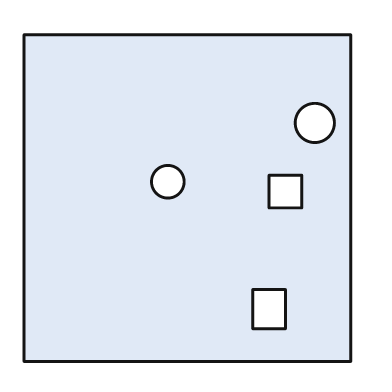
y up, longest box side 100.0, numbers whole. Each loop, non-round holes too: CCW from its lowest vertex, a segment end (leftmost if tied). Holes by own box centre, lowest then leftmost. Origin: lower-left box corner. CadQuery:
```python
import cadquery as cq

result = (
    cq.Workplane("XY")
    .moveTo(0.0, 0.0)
    .lineTo(100.0, 0.0)
    .lineTo(100.0, 100.0)
    .lineTo(0.0, 100.0)
    .close()
    .moveTo(70.0, 10.0)
    .lineTo(80.0, 10.0)
    .lineTo(80.0, 22.0)
    .lineTo(70.0, 22.0)
    .close()
    .moveTo(75.0, 47.0)
    .lineTo(85.0, 47.0)
    .lineTo(85.0, 57.0)
    .lineTo(75.0, 57.0)
    .close()
    .moveTo(44.0, 55.0)
    .circle(5.0)
    .moveTo(89.0, 73.0)
    .circle(6.0)
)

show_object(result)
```